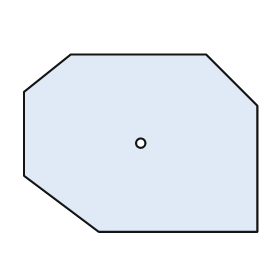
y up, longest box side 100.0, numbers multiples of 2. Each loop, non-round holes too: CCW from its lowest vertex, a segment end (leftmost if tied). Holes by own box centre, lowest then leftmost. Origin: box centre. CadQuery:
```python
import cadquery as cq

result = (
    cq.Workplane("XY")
    .moveTo(-18.0, -38.0)
    .lineTo(50.0, -38.0)
    .lineTo(50.0, 16.0)
    .lineTo(28.0, 38.0)
    .lineTo(-30.0, 38.0)
    .lineTo(-50.0, 22.0)
    .lineTo(-50.0, -14.0)
    .close()
    .moveTo(0.0, 0.0)
    .circle(2.0)
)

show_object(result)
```